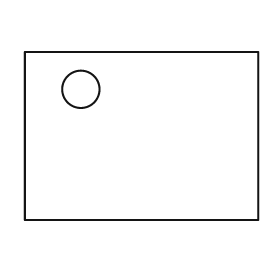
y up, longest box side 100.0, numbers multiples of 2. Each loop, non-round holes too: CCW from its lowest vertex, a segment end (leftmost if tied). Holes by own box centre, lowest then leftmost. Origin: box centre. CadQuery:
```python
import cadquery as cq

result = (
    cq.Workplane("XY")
    .moveTo(-50.0, -36.0)
    .lineTo(50.0, -36.0)
    .lineTo(50.0, 36.0)
    .lineTo(-50.0, 36.0)
    .close()
    .moveTo(-26.0, 20.0)
    .circle(8.0)
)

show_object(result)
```